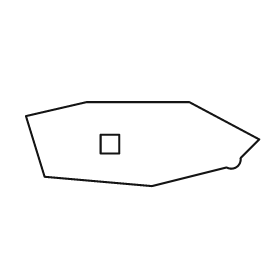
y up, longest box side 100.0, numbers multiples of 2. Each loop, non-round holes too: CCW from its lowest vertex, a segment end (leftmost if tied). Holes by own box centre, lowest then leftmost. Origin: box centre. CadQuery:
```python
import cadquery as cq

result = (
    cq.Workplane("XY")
    .moveTo(4.0, -18.0)
    .lineTo(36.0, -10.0)
    .threePointArc((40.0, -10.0), (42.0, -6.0))
    .lineTo(50.0, 2.0)
    .lineTo(20.0, 18.0)
    .lineTo(-24.0, 18.0)
    .lineTo(-50.0, 12.0)
    .lineTo(-42.0, -14.0)
    .close()
    .moveTo(-18.0, -4.0)
    .lineTo(-10.0, -4.0)
    .lineTo(-10.0, 4.0)
    .lineTo(-18.0, 4.0)
    .close()
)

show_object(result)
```